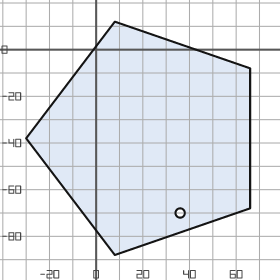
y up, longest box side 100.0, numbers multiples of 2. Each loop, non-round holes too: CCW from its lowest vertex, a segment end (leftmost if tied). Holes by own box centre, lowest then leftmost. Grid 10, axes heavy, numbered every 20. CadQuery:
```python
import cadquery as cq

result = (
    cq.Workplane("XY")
    .moveTo(8.0, -88.0)
    .lineTo(66.0, -68.0)
    .lineTo(66.0, -8.0)
    .lineTo(8.0, 12.0)
    .lineTo(-30.0, -38.0)
    .close()
    .moveTo(36.0, -70.0)
    .circle(2.0)
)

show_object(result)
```